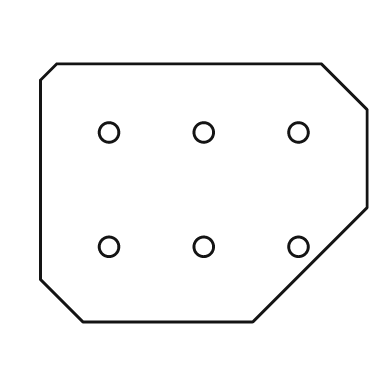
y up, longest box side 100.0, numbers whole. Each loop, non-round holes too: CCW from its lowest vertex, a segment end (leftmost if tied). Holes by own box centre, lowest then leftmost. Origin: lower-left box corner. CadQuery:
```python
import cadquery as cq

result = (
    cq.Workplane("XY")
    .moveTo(13.0, 0.0)
    .lineTo(65.0, 0.0)
    .lineTo(100.0, 35.0)
    .lineTo(100.0, 65.0)
    .lineTo(86.0, 79.0)
    .lineTo(5.0, 79.0)
    .lineTo(0.0, 74.0)
    .lineTo(0.0, 13.0)
    .close()
    .moveTo(21.0, 23.0)
    .circle(3.0)
    .moveTo(50.0, 23.0)
    .circle(3.0)
    .moveTo(79.0, 23.0)
    .circle(3.0)
    .moveTo(21.0, 58.0)
    .circle(3.0)
    .moveTo(50.0, 58.0)
    .circle(3.0)
    .moveTo(79.0, 58.0)
    .circle(3.0)
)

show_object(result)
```